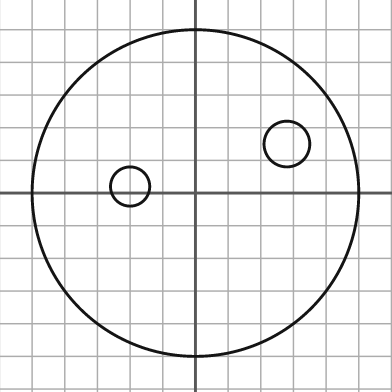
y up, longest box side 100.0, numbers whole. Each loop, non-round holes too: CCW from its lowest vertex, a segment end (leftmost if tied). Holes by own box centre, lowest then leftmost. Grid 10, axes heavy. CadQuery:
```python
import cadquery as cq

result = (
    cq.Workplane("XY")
    .moveTo(0.0, 0.0)
    .circle(50.0)
    .moveTo(-20.0, 2.0)
    .circle(6.0)
    .moveTo(28.0, 15.0)
    .circle(7.0)
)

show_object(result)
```